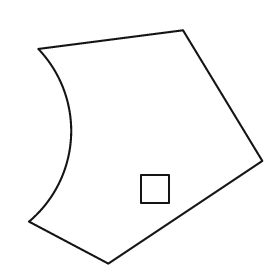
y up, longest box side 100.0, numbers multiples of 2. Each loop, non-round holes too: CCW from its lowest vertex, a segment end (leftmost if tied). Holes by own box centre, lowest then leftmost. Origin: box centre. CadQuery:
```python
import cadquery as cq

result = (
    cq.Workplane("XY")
    .moveTo(-16.0, -50.0)
    .lineTo(50.0, -6.0)
    .lineTo(16.0, 50.0)
    .lineTo(-46.0, 42.0)
    .threePointArc((-32.0, 4.0), (-50.0, -32.0))
    .close()
    .moveTo(-2.0, -24.0)
    .lineTo(10.0, -24.0)
    .lineTo(10.0, -12.0)
    .lineTo(-2.0, -12.0)
    .close()
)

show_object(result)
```